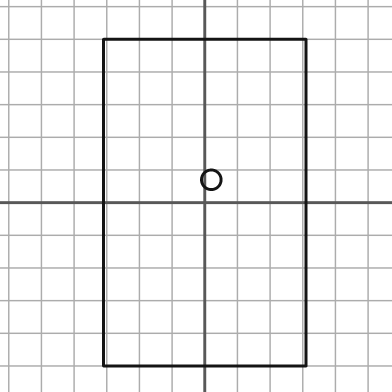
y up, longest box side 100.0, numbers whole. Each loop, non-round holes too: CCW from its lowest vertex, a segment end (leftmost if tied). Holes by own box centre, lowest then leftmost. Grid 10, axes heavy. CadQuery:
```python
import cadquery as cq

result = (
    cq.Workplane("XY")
    .moveTo(-31.0, -50.0)
    .lineTo(31.0, -50.0)
    .lineTo(31.0, 50.0)
    .lineTo(-31.0, 50.0)
    .close()
    .moveTo(2.0, 7.0)
    .circle(3.0)
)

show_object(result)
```